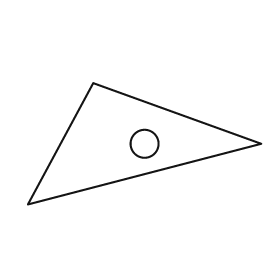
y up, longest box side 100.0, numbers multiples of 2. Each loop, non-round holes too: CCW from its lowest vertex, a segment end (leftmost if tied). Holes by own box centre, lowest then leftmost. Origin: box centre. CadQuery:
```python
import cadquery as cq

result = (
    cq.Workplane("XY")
    .moveTo(-50.0, -26.0)
    .lineTo(50.0, 0.0)
    .lineTo(-22.0, 26.0)
    .close()
    .moveTo(0.0, 0.0)
    .circle(6.0)
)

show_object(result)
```